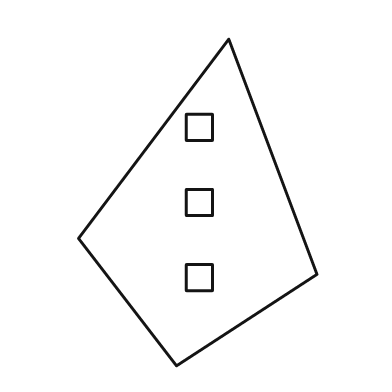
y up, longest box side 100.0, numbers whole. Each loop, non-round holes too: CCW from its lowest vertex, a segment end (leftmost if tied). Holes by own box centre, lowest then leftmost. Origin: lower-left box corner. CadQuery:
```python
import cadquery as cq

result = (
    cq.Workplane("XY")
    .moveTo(30.0, 0.0)
    .lineTo(73.0, 28.0)
    .lineTo(46.0, 100.0)
    .lineTo(0.0, 39.0)
    .close()
    .moveTo(33.0, 23.0)
    .lineTo(41.0, 23.0)
    .lineTo(41.0, 31.0)
    .lineTo(33.0, 31.0)
    .close()
    .moveTo(33.0, 46.0)
    .lineTo(41.0, 46.0)
    .lineTo(41.0, 54.0)
    .lineTo(33.0, 54.0)
    .close()
    .moveTo(33.0, 69.0)
    .lineTo(41.0, 69.0)
    .lineTo(41.0, 77.0)
    .lineTo(33.0, 77.0)
    .close()
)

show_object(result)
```